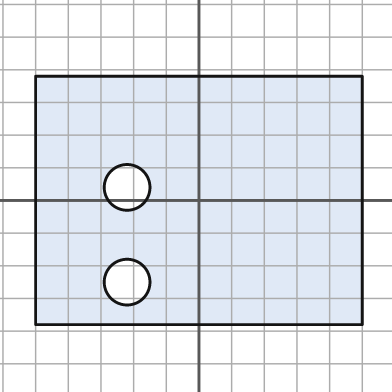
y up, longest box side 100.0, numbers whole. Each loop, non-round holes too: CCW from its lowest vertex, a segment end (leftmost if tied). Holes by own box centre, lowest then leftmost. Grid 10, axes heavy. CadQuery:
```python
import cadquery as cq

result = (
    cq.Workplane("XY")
    .moveTo(-50.0, -38.0)
    .lineTo(50.0, -38.0)
    .lineTo(50.0, 38.0)
    .lineTo(-50.0, 38.0)
    .close()
    .moveTo(-22.0, -25.0)
    .circle(7.0)
    .moveTo(-22.0, 4.0)
    .circle(7.0)
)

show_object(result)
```